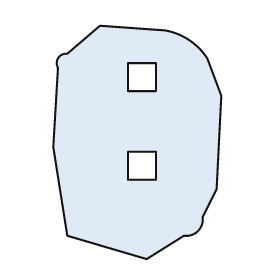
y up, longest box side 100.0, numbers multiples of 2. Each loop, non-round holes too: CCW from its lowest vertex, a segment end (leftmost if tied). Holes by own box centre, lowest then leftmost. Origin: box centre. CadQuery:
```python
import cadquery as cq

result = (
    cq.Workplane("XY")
    .moveTo(4.0, -50.0)
    .lineTo(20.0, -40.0)
    .threePointArc((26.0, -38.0), (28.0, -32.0))
    .lineTo(34.0, -20.0)
    .lineTo(36.0, 20.0)
    .lineTo(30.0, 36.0)
    .threePointArc((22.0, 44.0), (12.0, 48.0))
    .lineTo(-16.0, 50.0)
    .lineTo(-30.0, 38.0)
    .threePointArc((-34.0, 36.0), (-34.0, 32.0))
    .lineTo(-36.0, -2.0)
    .lineTo(-30.0, -40.0)
    .close()
    .moveTo(-4.0, -16.0)
    .lineTo(8.0, -16.0)
    .lineTo(8.0, -4.0)
    .lineTo(-4.0, -4.0)
    .close()
    .moveTo(-4.0, 22.0)
    .lineTo(8.0, 22.0)
    .lineTo(8.0, 34.0)
    .lineTo(-4.0, 34.0)
    .close()
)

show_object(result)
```